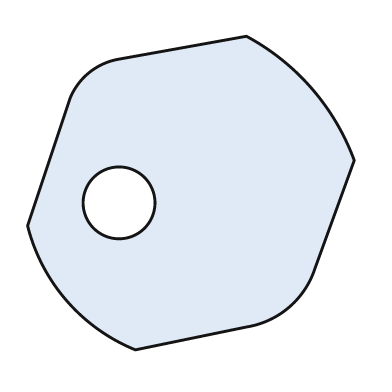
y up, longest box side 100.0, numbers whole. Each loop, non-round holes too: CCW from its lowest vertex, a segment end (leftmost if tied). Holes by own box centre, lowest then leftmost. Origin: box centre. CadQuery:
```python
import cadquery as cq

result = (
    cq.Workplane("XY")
    .moveTo(-17.0, -48.0)
    .lineTo(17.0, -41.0)
    .threePointArc((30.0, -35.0), (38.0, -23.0))
    .lineTo(50.0, 10.0)
    .threePointArc((37.0, 32.0), (17.0, 48.0))
    .lineTo(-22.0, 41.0)
    .threePointArc((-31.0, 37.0), (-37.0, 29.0))
    .lineTo(-50.0, -10.0)
    .threePointArc((-38.0, -33.0), (-17.0, -48.0))
    .close()
    .moveTo(-22.0, -3.0)
    .circle(11.0)
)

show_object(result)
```